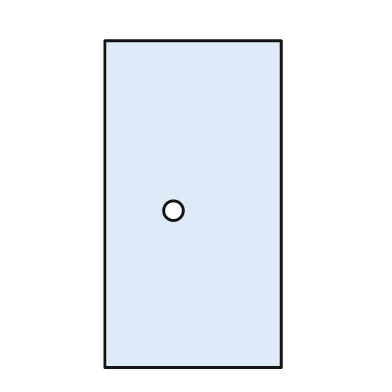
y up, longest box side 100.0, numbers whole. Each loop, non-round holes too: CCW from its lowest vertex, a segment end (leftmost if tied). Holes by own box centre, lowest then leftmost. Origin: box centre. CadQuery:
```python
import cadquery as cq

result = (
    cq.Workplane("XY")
    .moveTo(-27.0, -50.0)
    .lineTo(27.0, -50.0)
    .lineTo(27.0, 50.0)
    .lineTo(-27.0, 50.0)
    .close()
    .moveTo(-6.0, -2.0)
    .circle(3.0)
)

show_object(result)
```